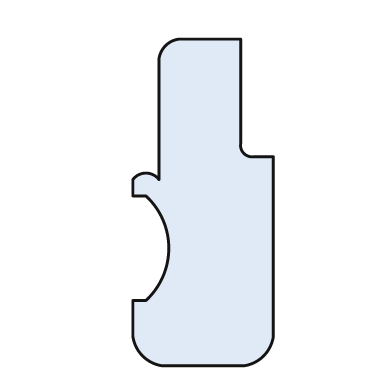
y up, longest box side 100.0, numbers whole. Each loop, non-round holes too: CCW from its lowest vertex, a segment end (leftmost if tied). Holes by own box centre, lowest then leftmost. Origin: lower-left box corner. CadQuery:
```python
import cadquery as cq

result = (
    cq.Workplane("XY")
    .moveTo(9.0, 0.0)
    .lineTo(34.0, 0.0)
    .threePointArc((40.0, 3.0), (43.0, 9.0))
    .lineTo(43.0, 64.0)
    .lineTo(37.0, 64.0)
    .threePointArc((34.0, 65.0), (33.0, 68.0))
    .lineTo(33.0, 100.0)
    .lineTo(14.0, 100.0)
    .threePointArc((10.0, 98.0), (8.0, 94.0))
    .lineTo(8.0, 57.0)
    .threePointArc((4.0, 59.0), (0.0, 57.0))
    .lineTo(0.0, 52.0)
    .lineTo(4.0, 52.0)
    .threePointArc((11.0, 36.0), (4.0, 20.0))
    .lineTo(0.0, 20.0)
    .lineTo(0.0, 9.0)
    .threePointArc((3.0, 3.0), (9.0, 0.0))
    .close()
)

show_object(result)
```